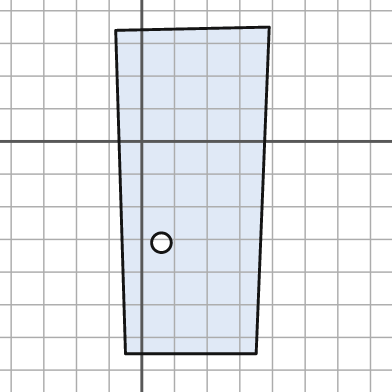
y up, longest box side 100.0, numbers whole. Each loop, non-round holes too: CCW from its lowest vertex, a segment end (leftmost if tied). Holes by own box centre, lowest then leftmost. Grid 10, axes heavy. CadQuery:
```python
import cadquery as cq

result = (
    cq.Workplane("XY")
    .moveTo(-5.0, -65.0)
    .lineTo(35.0, -65.0)
    .lineTo(39.0, 35.0)
    .lineTo(-8.0, 34.0)
    .close()
    .moveTo(6.0, -31.0)
    .circle(3.0)
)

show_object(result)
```